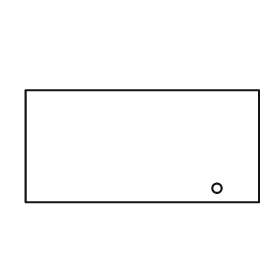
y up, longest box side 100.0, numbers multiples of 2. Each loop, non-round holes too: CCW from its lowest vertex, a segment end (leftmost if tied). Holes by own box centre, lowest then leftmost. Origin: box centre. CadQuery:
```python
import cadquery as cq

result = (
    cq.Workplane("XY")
    .moveTo(-50.0, -24.0)
    .lineTo(50.0, -24.0)
    .lineTo(50.0, 24.0)
    .lineTo(-50.0, 24.0)
    .close()
    .moveTo(32.0, -18.0)
    .circle(2.0)
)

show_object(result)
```